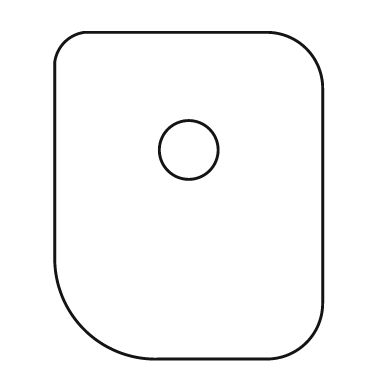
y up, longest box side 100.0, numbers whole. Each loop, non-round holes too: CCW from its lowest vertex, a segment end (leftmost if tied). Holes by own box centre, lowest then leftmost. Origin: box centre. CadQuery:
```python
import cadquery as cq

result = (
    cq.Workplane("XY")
    .moveTo(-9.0, -50.0)
    .lineTo(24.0, -50.0)
    .threePointArc((36.0, -45.0), (41.0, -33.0))
    .lineTo(41.0, 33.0)
    .threePointArc((36.0, 45.0), (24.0, 50.0))
    .lineTo(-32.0, 50.0)
    .threePointArc((-38.0, 47.0), (-41.0, 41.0))
    .lineTo(-41.0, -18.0)
    .threePointArc((-32.0, -41.0), (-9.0, -50.0))
    .close()
    .moveTo(0.0, 14.0)
    .circle(9.0)
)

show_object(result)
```